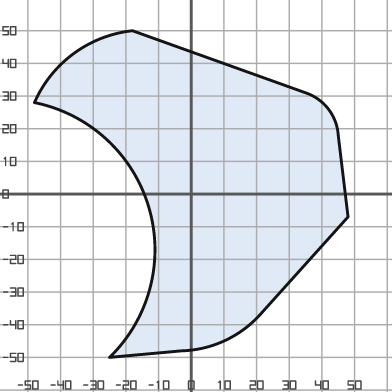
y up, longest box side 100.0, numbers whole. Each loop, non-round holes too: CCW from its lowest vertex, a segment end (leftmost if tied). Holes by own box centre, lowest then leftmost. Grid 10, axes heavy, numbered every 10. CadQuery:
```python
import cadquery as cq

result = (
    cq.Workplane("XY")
    .moveTo(-25.0, -50.0)
    .lineTo(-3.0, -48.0)
    .threePointArc((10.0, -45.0), (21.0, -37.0))
    .lineTo(48.0, -7.0)
    .lineTo(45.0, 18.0)
    .threePointArc((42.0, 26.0), (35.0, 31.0))
    .lineTo(-18.0, 50.0)
    .threePointArc((-36.0, 43.0), (-48.0, 28.0))
    .threePointArc((-13.0, -4.0), (-25.0, -50.0))
    .close()
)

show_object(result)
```